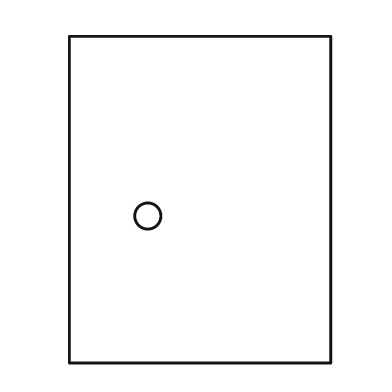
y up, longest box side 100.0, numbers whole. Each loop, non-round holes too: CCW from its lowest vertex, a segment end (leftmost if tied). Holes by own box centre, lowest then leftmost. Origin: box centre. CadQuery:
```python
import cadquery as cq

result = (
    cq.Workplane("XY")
    .moveTo(-40.0, -50.0)
    .lineTo(40.0, -50.0)
    .lineTo(40.0, 50.0)
    .lineTo(-40.0, 50.0)
    .close()
    .moveTo(-16.0, -5.0)
    .circle(4.0)
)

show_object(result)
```